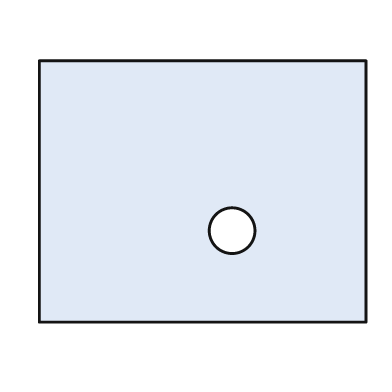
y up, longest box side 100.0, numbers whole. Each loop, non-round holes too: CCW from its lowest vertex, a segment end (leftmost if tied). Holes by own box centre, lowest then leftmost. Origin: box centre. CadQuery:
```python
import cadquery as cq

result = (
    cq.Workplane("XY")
    .moveTo(-50.0, -40.0)
    .lineTo(50.0, -40.0)
    .lineTo(50.0, 40.0)
    .lineTo(-50.0, 40.0)
    .close()
    .moveTo(9.0, -12.0)
    .circle(7.0)
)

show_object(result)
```